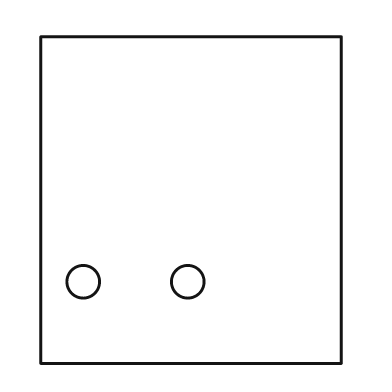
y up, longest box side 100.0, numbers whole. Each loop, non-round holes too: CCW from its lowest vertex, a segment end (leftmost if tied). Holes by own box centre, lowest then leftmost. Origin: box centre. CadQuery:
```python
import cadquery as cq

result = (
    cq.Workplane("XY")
    .moveTo(-46.0, -50.0)
    .lineTo(46.0, -50.0)
    .lineTo(46.0, 50.0)
    .lineTo(-46.0, 50.0)
    .close()
    .moveTo(-33.0, -25.0)
    .circle(5.0)
    .moveTo(-1.0, -25.0)
    .circle(5.0)
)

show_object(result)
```